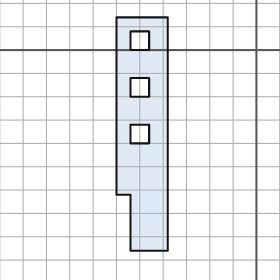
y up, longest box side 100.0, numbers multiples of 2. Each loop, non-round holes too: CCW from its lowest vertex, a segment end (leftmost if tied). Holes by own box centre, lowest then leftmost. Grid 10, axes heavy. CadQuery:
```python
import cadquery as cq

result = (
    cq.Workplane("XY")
    .moveTo(-54.0, -86.0)
    .lineTo(-38.0, -86.0)
    .lineTo(-38.0, 14.0)
    .lineTo(-60.0, 14.0)
    .lineTo(-60.0, -62.0)
    .lineTo(-54.0, -62.0)
    .close()
    .moveTo(-54.0, -40.0)
    .lineTo(-46.0, -40.0)
    .lineTo(-46.0, -32.0)
    .lineTo(-54.0, -32.0)
    .close()
    .moveTo(-54.0, -20.0)
    .lineTo(-46.0, -20.0)
    .lineTo(-46.0, -12.0)
    .lineTo(-54.0, -12.0)
    .close()
    .moveTo(-54.0, 0.0)
    .lineTo(-46.0, 0.0)
    .lineTo(-46.0, 8.0)
    .lineTo(-54.0, 8.0)
    .close()
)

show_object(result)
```